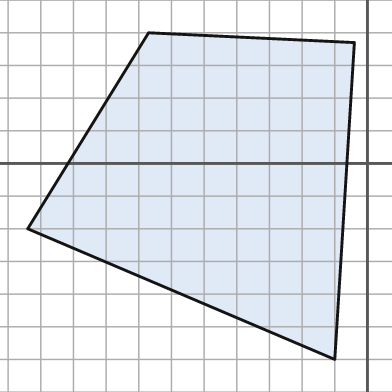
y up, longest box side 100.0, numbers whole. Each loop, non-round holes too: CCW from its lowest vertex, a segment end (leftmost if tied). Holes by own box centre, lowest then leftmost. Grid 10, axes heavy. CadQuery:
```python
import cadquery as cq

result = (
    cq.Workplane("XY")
    .moveTo(-10.0, -60.0)
    .lineTo(-4.0, 37.0)
    .lineTo(-67.0, 40.0)
    .lineTo(-104.0, -20.0)
    .close()
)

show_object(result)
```